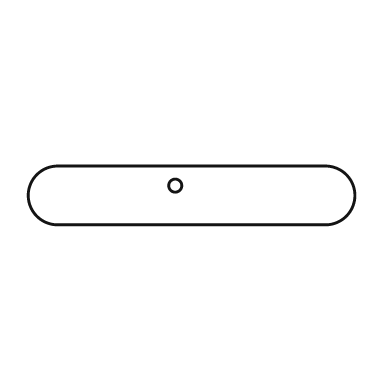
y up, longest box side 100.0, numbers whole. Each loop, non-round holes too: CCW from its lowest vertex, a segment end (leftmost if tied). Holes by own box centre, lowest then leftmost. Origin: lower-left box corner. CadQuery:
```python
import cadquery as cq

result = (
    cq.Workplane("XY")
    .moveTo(9.0, 0.0)
    .lineTo(91.0, 0.0)
    .threePointArc((100.0, 9.0), (91.0, 18.0))
    .lineTo(9.0, 18.0)
    .threePointArc((0.0, 9.0), (9.0, 0.0))
    .close()
    .moveTo(45.0, 12.0)
    .circle(2.0)
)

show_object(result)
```